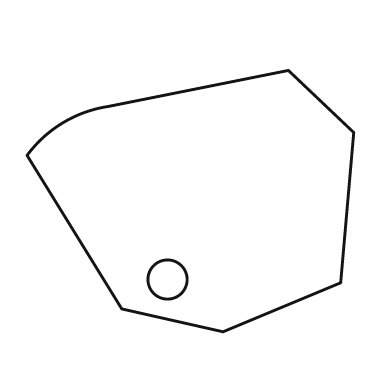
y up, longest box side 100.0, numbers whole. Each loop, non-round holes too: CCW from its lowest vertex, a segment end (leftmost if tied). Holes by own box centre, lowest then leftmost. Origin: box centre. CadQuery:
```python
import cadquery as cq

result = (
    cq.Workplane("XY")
    .moveTo(10.0, -40.0)
    .lineTo(46.0, -25.0)
    .lineTo(50.0, 21.0)
    .lineTo(30.0, 40.0)
    .lineTo(-25.0, 29.0)
    .threePointArc((-39.0, 24.0), (-50.0, 14.0))
    .lineTo(-21.0, -33.0)
    .close()
    .moveTo(-7.0, -24.0)
    .circle(6.0)
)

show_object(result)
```